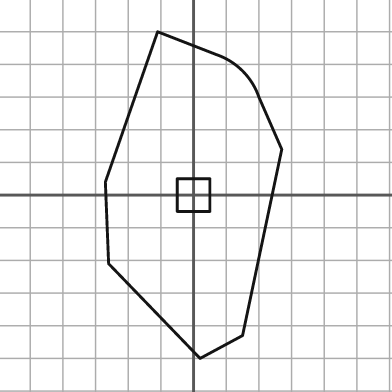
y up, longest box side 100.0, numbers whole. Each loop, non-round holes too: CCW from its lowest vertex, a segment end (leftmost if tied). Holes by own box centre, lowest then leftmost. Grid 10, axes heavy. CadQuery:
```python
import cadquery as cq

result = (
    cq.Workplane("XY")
    .moveTo(2.0, -50.0)
    .lineTo(15.0, -43.0)
    .lineTo(27.0, 14.0)
    .lineTo(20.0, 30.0)
    .threePointArc((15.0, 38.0), (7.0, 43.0))
    .lineTo(-11.0, 50.0)
    .lineTo(-27.0, 4.0)
    .lineTo(-26.0, -21.0)
    .close()
    .moveTo(-5.0, -5.0)
    .lineTo(5.0, -5.0)
    .lineTo(5.0, 5.0)
    .lineTo(-5.0, 5.0)
    .close()
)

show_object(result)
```